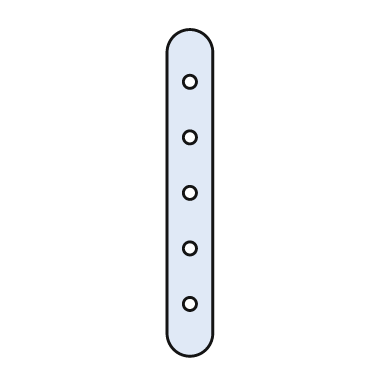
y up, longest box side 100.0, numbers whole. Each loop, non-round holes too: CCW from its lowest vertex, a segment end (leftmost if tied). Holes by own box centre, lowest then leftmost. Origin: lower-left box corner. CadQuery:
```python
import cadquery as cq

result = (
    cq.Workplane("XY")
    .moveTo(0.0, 7.0)
    .threePointArc((7.0, 0.0), (14.0, 7.0))
    .lineTo(14.0, 93.0)
    .threePointArc((7.0, 100.0), (0.0, 93.0))
    .close()
    .moveTo(7.0, 16.0)
    .circle(2.0)
    .moveTo(7.0, 33.0)
    .circle(2.0)
    .moveTo(7.0, 50.0)
    .circle(2.0)
    .moveTo(7.0, 67.0)
    .circle(2.0)
    .moveTo(7.0, 84.0)
    .circle(2.0)
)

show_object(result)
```